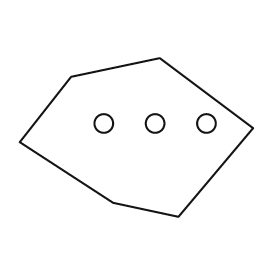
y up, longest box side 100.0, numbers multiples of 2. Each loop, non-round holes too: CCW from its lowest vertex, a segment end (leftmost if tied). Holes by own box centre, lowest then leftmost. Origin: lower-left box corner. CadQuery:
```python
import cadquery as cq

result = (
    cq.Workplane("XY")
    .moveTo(68.0, 0.0)
    .lineTo(100.0, 38.0)
    .lineTo(60.0, 68.0)
    .lineTo(22.0, 60.0)
    .lineTo(0.0, 32.0)
    .lineTo(40.0, 6.0)
    .close()
    .moveTo(36.0, 40.0)
    .circle(4.0)
    .moveTo(58.0, 40.0)
    .circle(4.0)
    .moveTo(80.0, 40.0)
    .circle(4.0)
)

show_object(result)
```